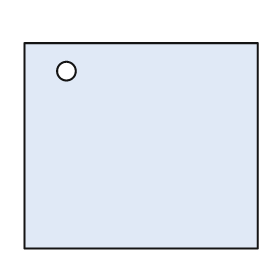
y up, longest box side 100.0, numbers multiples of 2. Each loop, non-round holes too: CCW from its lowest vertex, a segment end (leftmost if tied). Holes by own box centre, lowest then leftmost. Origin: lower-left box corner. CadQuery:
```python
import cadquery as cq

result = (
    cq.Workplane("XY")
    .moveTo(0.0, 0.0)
    .lineTo(100.0, 0.0)
    .lineTo(100.0, 88.0)
    .lineTo(0.0, 88.0)
    .close()
    .moveTo(18.0, 76.0)
    .circle(4.0)
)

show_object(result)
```